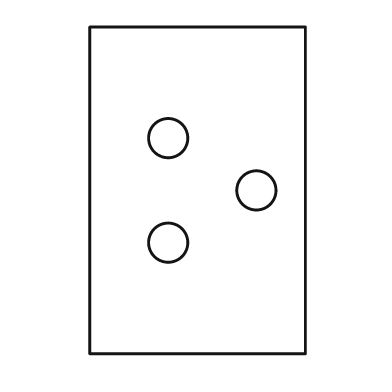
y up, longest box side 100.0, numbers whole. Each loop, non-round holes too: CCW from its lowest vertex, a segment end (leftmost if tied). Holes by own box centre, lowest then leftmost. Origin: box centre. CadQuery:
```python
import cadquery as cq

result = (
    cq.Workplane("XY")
    .moveTo(-33.0, -50.0)
    .lineTo(33.0, -50.0)
    .lineTo(33.0, 50.0)
    .lineTo(-33.0, 50.0)
    .close()
    .moveTo(-9.0, -16.0)
    .circle(6.0)
    .moveTo(18.0, 0.0)
    .circle(6.0)
    .moveTo(-9.0, 16.0)
    .circle(6.0)
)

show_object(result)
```